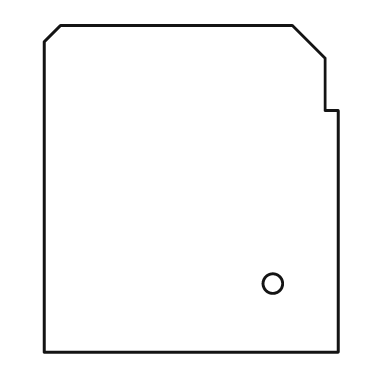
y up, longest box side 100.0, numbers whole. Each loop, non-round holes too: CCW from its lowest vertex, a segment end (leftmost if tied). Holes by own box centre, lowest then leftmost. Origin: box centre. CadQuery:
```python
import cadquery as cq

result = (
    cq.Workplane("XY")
    .moveTo(-45.0, -50.0)
    .lineTo(45.0, -50.0)
    .lineTo(45.0, 24.0)
    .lineTo(41.0, 24.0)
    .lineTo(41.0, 40.0)
    .lineTo(31.0, 50.0)
    .lineTo(-40.0, 50.0)
    .lineTo(-45.0, 45.0)
    .close()
    .moveTo(25.0, -29.0)
    .circle(3.0)
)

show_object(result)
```